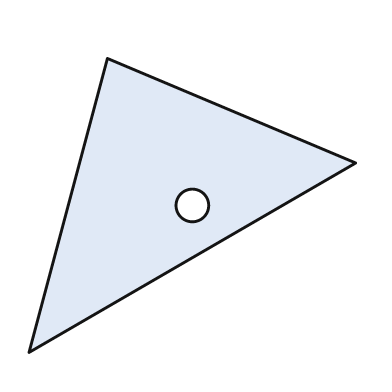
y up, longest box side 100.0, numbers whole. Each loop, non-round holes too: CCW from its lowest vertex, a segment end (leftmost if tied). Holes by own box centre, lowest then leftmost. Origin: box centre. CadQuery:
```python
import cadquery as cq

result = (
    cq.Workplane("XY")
    .moveTo(-50.0, -45.0)
    .lineTo(50.0, 13.0)
    .lineTo(-26.0, 45.0)
    .close()
    .moveTo(0.0, 0.0)
    .circle(5.0)
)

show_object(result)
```